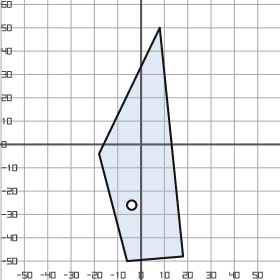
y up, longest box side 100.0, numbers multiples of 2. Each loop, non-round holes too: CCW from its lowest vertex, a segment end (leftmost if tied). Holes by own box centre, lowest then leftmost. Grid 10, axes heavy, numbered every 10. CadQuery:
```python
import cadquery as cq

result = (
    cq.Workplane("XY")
    .moveTo(-6.0, -50.0)
    .lineTo(18.0, -48.0)
    .lineTo(8.0, 50.0)
    .lineTo(-18.0, -4.0)
    .close()
    .moveTo(-4.0, -26.0)
    .circle(2.0)
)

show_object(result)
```